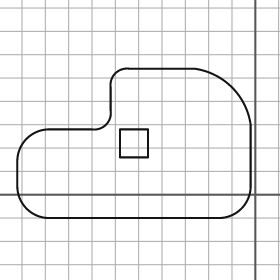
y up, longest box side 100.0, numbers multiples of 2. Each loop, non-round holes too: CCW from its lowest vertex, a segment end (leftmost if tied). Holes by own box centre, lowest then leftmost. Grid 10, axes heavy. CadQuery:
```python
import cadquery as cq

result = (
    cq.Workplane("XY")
    .moveTo(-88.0, -10.0)
    .lineTo(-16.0, -10.0)
    .threePointArc((-6.0, -6.0), (-2.0, 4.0))
    .lineTo(-2.0, 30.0)
    .threePointArc((-10.0, 46.0), (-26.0, 54.0))
    .lineTo(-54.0, 54.0)
    .threePointArc((-60.0, 52.0), (-62.0, 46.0))
    .lineTo(-62.0, 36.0)
    .threePointArc((-64.0, 30.0), (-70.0, 28.0))
    .lineTo(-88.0, 28.0)
    .threePointArc((-98.0, 24.0), (-102.0, 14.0))
    .lineTo(-102.0, 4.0)
    .threePointArc((-98.0, -6.0), (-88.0, -10.0))
    .close()
    .moveTo(-58.0, 16.0)
    .lineTo(-46.0, 16.0)
    .lineTo(-46.0, 28.0)
    .lineTo(-58.0, 28.0)
    .close()
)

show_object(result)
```